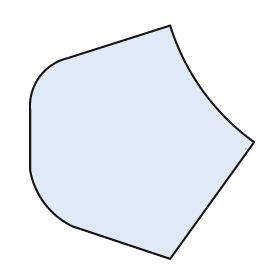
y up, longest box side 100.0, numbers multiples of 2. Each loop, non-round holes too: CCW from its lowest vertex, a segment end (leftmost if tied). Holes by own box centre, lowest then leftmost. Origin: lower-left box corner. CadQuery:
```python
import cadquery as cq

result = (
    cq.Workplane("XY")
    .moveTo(60.0, 0.0)
    .lineTo(96.0, 50.0)
    .threePointArc((74.0, 72.0), (60.0, 100.0))
    .lineTo(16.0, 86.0)
    .threePointArc((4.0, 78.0), (0.0, 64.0))
    .lineTo(0.0, 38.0)
    .threePointArc((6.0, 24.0), (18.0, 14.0))
    .close()
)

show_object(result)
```